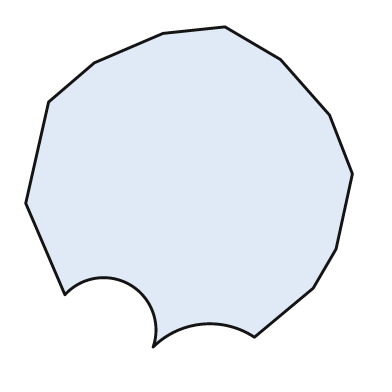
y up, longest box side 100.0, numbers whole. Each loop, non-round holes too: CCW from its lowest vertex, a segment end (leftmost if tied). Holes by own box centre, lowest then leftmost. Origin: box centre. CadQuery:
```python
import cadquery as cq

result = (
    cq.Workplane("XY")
    .moveTo(-11.0, -49.0)
    .threePointArc((4.0, -42.0), (20.0, -46.0))
    .lineTo(38.0, -31.0)
    .lineTo(45.0, -19.0)
    .lineTo(50.0, 4.0)
    .lineTo(43.0, 22.0)
    .lineTo(28.0, 39.0)
    .lineTo(11.0, 49.0)
    .lineTo(-8.0, 47.0)
    .lineTo(-29.0, 38.0)
    .lineTo(-43.0, 26.0)
    .lineTo(-50.0, -5.0)
    .lineTo(-38.0, -33.0)
    .threePointArc((-18.0, -30.0), (-11.0, -49.0))
    .close()
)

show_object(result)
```